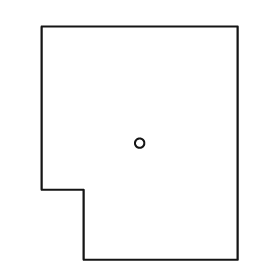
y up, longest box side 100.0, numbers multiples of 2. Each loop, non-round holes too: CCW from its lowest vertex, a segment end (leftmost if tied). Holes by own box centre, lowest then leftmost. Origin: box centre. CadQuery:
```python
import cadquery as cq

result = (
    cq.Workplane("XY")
    .moveTo(-24.0, -50.0)
    .lineTo(42.0, -50.0)
    .lineTo(42.0, 50.0)
    .lineTo(-42.0, 50.0)
    .lineTo(-42.0, -20.0)
    .lineTo(-24.0, -20.0)
    .close()
    .moveTo(0.0, 0.0)
    .circle(2.0)
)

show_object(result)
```